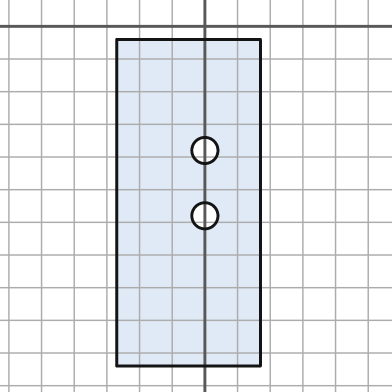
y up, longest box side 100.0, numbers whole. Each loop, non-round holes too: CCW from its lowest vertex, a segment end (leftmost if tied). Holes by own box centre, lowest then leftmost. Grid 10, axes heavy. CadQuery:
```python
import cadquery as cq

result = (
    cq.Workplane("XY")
    .moveTo(-27.0, -104.0)
    .lineTo(17.0, -104.0)
    .lineTo(17.0, -4.0)
    .lineTo(-27.0, -4.0)
    .close()
    .moveTo(0.0, -58.0)
    .circle(4.0)
    .moveTo(0.0, -38.0)
    .circle(4.0)
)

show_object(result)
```